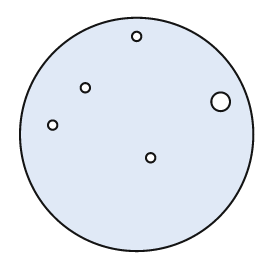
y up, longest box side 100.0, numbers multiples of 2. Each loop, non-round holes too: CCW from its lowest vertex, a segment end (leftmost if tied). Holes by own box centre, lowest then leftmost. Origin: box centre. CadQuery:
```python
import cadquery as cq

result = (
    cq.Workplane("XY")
    .moveTo(0.0, 0.0)
    .circle(50.0)
    .moveTo(6.0, -10.0)
    .circle(2.0)
    .moveTo(-36.0, 4.0)
    .circle(2.0)
    .moveTo(36.0, 14.0)
    .circle(4.0)
    .moveTo(-22.0, 20.0)
    .circle(2.0)
    .moveTo(0.0, 42.0)
    .circle(2.0)
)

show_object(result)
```